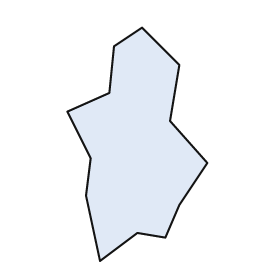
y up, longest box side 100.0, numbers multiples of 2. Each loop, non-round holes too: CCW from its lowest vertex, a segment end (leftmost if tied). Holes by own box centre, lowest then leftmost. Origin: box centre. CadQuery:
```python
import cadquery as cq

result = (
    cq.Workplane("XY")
    .moveTo(-16.0, -50.0)
    .lineTo(0.0, -38.0)
    .lineTo(12.0, -40.0)
    .lineTo(18.0, -26.0)
    .lineTo(30.0, -8.0)
    .lineTo(14.0, 10.0)
    .lineTo(18.0, 34.0)
    .lineTo(2.0, 50.0)
    .lineTo(-10.0, 42.0)
    .lineTo(-12.0, 22.0)
    .lineTo(-30.0, 14.0)
    .lineTo(-20.0, -6.0)
    .lineTo(-22.0, -22.0)
    .close()
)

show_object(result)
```